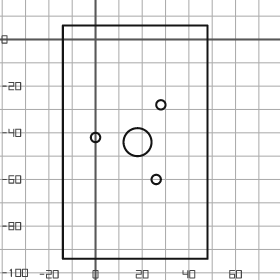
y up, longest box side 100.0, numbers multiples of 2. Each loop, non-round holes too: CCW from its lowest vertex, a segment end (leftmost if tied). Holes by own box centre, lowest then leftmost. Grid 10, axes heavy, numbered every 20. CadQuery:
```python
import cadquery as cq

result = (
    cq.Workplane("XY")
    .moveTo(-14.0, -94.0)
    .lineTo(48.0, -94.0)
    .lineTo(48.0, 6.0)
    .lineTo(-14.0, 6.0)
    .close()
    .moveTo(26.0, -60.0)
    .circle(2.0)
    .moveTo(18.0, -44.0)
    .circle(6.0)
    .moveTo(0.0, -42.0)
    .circle(2.0)
    .moveTo(28.0, -28.0)
    .circle(2.0)
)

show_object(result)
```